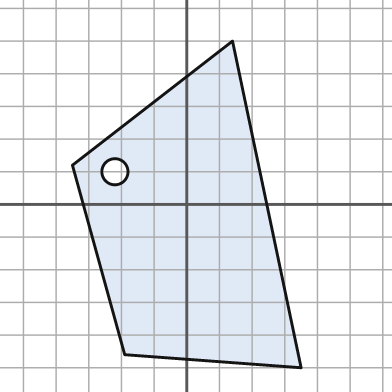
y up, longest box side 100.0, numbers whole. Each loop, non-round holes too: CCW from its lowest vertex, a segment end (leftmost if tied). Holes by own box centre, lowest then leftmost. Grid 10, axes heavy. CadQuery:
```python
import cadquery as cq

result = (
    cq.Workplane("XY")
    .moveTo(35.0, -50.0)
    .lineTo(14.0, 50.0)
    .lineTo(-35.0, 12.0)
    .lineTo(-19.0, -46.0)
    .close()
    .moveTo(-22.0, 10.0)
    .circle(4.0)
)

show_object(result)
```